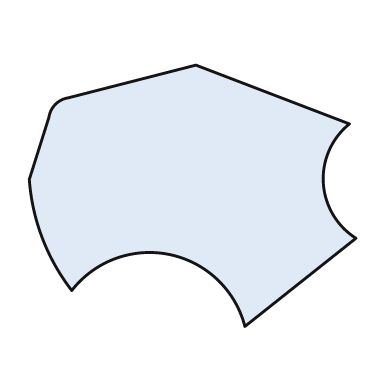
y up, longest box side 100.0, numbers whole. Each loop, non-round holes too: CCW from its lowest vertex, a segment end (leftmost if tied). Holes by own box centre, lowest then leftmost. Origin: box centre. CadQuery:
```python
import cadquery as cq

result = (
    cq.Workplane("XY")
    .moveTo(16.0, -40.0)
    .lineTo(50.0, -13.0)
    .threePointArc((40.0, 4.0), (48.0, 22.0))
    .lineTo(1.0, 40.0)
    .lineTo(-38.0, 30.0)
    .threePointArc((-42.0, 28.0), (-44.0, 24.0))
    .lineTo(-50.0, 5.0)
    .threePointArc((-46.0, -13.0), (-37.0, -29.0))
    .threePointArc((-7.0, -18.0), (16.0, -40.0))
    .close()
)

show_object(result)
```